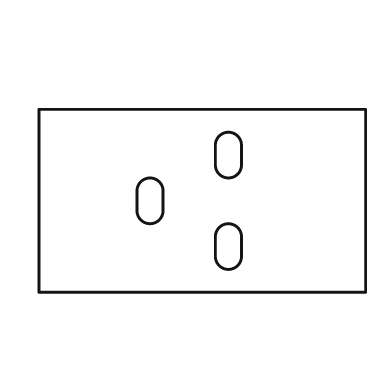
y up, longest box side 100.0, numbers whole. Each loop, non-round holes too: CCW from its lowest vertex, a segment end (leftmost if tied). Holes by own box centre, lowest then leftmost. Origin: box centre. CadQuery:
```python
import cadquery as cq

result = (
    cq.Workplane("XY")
    .moveTo(-50.0, -28.0)
    .lineTo(50.0, -28.0)
    .lineTo(50.0, 28.0)
    .lineTo(-50.0, 28.0)
    .close()
    .moveTo(4.0, -17.0)
    .threePointArc((8.0, -21.0), (12.0, -17.0))
    .lineTo(12.0, -11.0)
    .threePointArc((8.0, -7.0), (4.0, -11.0))
    .close()
    .moveTo(-20.0, -3.0)
    .threePointArc((-16.0, -7.0), (-12.0, -3.0))
    .lineTo(-12.0, 3.0)
    .threePointArc((-16.0, 7.0), (-20.0, 3.0))
    .close()
    .moveTo(4.0, 11.0)
    .threePointArc((8.0, 7.0), (12.0, 11.0))
    .lineTo(12.0, 17.0)
    .threePointArc((8.0, 21.0), (4.0, 17.0))
    .close()
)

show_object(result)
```